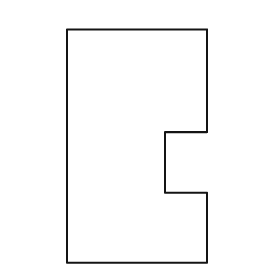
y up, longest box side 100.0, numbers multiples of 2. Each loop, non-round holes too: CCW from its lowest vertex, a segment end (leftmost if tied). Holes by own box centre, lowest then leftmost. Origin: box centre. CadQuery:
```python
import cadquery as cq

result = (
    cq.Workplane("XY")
    .moveTo(-30.0, -50.0)
    .lineTo(30.0, -50.0)
    .lineTo(30.0, -20.0)
    .lineTo(12.0, -20.0)
    .lineTo(12.0, 6.0)
    .lineTo(30.0, 6.0)
    .lineTo(30.0, 50.0)
    .lineTo(-30.0, 50.0)
    .close()
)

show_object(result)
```